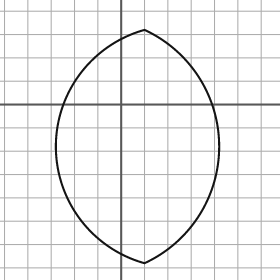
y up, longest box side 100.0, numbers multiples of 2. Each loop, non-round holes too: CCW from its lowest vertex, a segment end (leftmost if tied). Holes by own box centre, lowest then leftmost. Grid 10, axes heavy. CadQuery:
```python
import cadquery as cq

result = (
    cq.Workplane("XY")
    .moveTo(10.0, -68.0)
    .threePointArc((42.0, -18.0), (10.0, 32.0))
    .threePointArc((-28.0, -18.0), (10.0, -68.0))
    .close()
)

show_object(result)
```